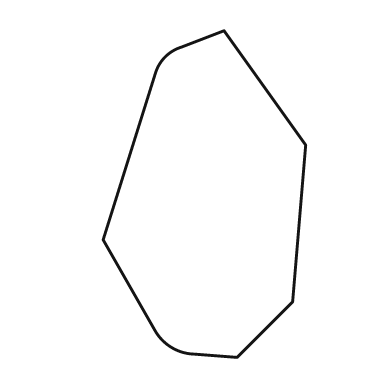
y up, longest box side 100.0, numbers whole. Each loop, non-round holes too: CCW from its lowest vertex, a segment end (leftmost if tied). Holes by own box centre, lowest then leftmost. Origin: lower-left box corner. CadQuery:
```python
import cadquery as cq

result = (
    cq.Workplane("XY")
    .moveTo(41.0, 0.0)
    .lineTo(58.0, 17.0)
    .lineTo(62.0, 65.0)
    .lineTo(37.0, 100.0)
    .lineTo(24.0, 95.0)
    .threePointArc((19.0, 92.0), (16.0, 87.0))
    .lineTo(0.0, 36.0)
    .lineTo(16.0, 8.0)
    .threePointArc((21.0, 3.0), (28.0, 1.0))
    .close()
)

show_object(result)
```